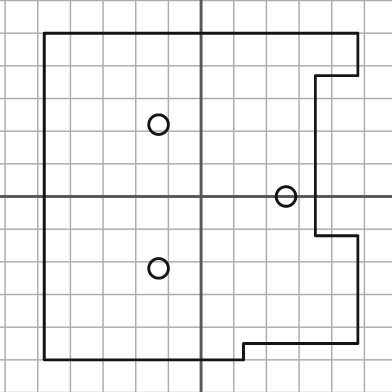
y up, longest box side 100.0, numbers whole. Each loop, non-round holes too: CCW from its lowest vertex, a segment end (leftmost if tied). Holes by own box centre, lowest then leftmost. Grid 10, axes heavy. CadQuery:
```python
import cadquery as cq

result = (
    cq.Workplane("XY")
    .moveTo(-48.0, -50.0)
    .lineTo(13.0, -50.0)
    .lineTo(13.0, -45.0)
    .lineTo(48.0, -45.0)
    .lineTo(48.0, -12.0)
    .lineTo(35.0, -12.0)
    .lineTo(35.0, 37.0)
    .lineTo(48.0, 37.0)
    .lineTo(48.0, 50.0)
    .lineTo(-48.0, 50.0)
    .close()
    .moveTo(-13.0, -22.0)
    .circle(3.0)
    .moveTo(26.0, 0.0)
    .circle(3.0)
    .moveTo(-13.0, 22.0)
    .circle(3.0)
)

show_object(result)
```